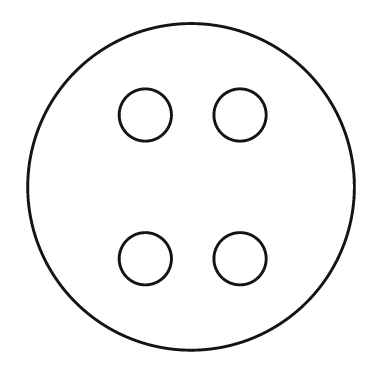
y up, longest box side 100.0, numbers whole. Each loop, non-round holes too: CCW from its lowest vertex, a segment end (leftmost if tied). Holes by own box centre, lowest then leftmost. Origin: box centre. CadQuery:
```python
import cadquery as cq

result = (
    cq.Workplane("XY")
    .moveTo(0.0, 0.0)
    .circle(50.0)
    .moveTo(-14.0, -22.0)
    .circle(8.0)
    .moveTo(15.0, -22.0)
    .circle(8.0)
    .moveTo(-14.0, 22.0)
    .circle(8.0)
    .moveTo(15.0, 22.0)
    .circle(8.0)
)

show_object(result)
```